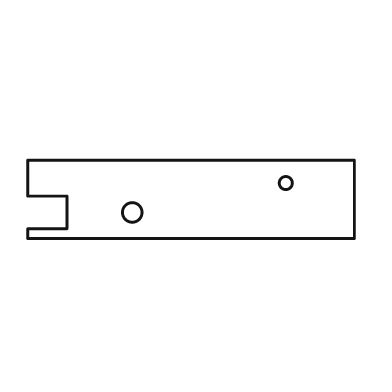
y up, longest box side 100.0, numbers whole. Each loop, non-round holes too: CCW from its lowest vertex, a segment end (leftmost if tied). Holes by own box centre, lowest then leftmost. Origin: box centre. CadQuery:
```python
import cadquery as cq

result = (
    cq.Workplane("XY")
    .moveTo(-50.0, -12.0)
    .lineTo(50.0, -12.0)
    .lineTo(50.0, 12.0)
    .lineTo(-50.0, 12.0)
    .lineTo(-50.0, 1.0)
    .lineTo(-38.0, 1.0)
    .lineTo(-38.0, -9.0)
    .lineTo(-50.0, -9.0)
    .close()
    .moveTo(-18.0, -4.0)
    .circle(3.0)
    .moveTo(29.0, 5.0)
    .circle(2.0)
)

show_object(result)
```